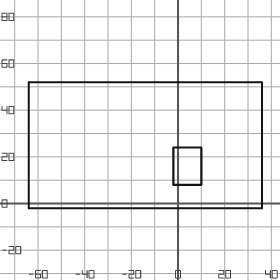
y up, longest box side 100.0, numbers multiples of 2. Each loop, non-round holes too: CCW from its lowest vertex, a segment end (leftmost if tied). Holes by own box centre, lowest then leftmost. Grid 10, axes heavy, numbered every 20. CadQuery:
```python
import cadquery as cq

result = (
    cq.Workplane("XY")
    .moveTo(-64.0, -2.0)
    .lineTo(36.0, -2.0)
    .lineTo(36.0, 52.0)
    .lineTo(-64.0, 52.0)
    .close()
    .moveTo(-2.0, 8.0)
    .lineTo(10.0, 8.0)
    .lineTo(10.0, 24.0)
    .lineTo(-2.0, 24.0)
    .close()
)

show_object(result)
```